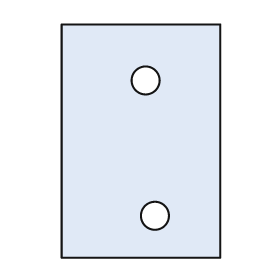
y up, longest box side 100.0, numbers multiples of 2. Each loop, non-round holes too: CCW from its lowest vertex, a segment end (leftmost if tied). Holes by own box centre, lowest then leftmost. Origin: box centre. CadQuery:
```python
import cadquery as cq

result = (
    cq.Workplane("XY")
    .moveTo(-34.0, -50.0)
    .lineTo(34.0, -50.0)
    .lineTo(34.0, 50.0)
    .lineTo(-34.0, 50.0)
    .close()
    .moveTo(6.0, -32.0)
    .circle(6.0)
    .moveTo(2.0, 26.0)
    .circle(6.0)
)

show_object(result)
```